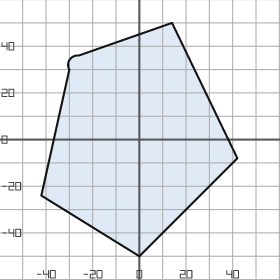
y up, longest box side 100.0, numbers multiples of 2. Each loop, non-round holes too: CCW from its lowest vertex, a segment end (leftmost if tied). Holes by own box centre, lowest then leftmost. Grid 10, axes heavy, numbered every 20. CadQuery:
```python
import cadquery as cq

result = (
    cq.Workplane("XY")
    .moveTo(0.0, -50.0)
    .lineTo(42.0, -8.0)
    .lineTo(14.0, 50.0)
    .lineTo(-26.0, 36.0)
    .threePointArc((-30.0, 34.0), (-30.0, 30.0))
    .lineTo(-42.0, -24.0)
    .close()
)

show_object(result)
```